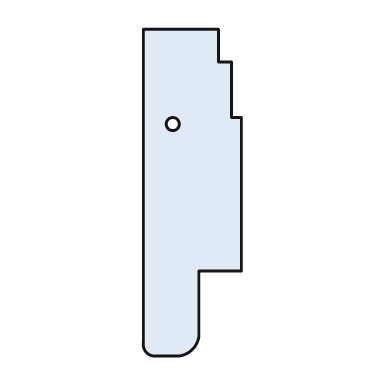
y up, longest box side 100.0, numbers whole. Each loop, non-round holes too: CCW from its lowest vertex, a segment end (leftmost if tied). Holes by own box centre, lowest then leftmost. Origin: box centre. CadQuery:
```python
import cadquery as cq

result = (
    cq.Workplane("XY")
    .moveTo(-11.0, -50.0)
    .lineTo(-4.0, -50.0)
    .threePointArc((0.0, -48.0), (2.0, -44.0))
    .lineTo(2.0, -24.0)
    .lineTo(15.0, -24.0)
    .lineTo(15.0, 23.0)
    .lineTo(12.0, 23.0)
    .lineTo(12.0, 40.0)
    .lineTo(8.0, 40.0)
    .lineTo(8.0, 50.0)
    .lineTo(-15.0, 50.0)
    .lineTo(-15.0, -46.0)
    .threePointArc((-14.0, -49.0), (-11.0, -50.0))
    .close()
    .moveTo(-6.0, 21.0)
    .circle(2.0)
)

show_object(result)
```